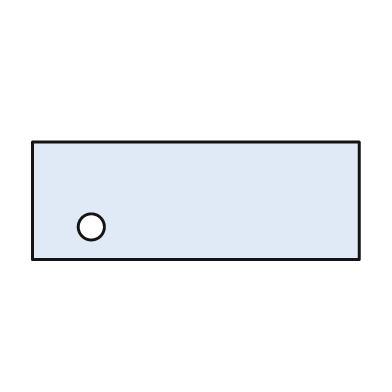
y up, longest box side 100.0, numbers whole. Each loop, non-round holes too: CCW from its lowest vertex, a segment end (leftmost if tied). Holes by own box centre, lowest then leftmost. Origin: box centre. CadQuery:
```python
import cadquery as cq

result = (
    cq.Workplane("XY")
    .moveTo(-50.0, -18.0)
    .lineTo(50.0, -18.0)
    .lineTo(50.0, 18.0)
    .lineTo(-50.0, 18.0)
    .close()
    .moveTo(-32.0, -8.0)
    .circle(4.0)
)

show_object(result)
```